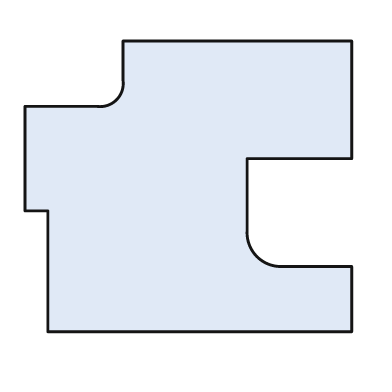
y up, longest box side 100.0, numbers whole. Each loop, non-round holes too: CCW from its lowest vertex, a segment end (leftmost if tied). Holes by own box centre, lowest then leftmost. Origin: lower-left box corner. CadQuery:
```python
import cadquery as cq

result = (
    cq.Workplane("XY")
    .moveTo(7.0, 0.0)
    .lineTo(100.0, 0.0)
    .lineTo(100.0, 20.0)
    .lineTo(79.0, 20.0)
    .threePointArc((71.0, 23.0), (68.0, 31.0))
    .lineTo(68.0, 53.0)
    .lineTo(100.0, 53.0)
    .lineTo(100.0, 89.0)
    .lineTo(30.0, 89.0)
    .lineTo(30.0, 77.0)
    .threePointArc((28.0, 71.0), (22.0, 69.0))
    .lineTo(0.0, 69.0)
    .lineTo(0.0, 37.0)
    .lineTo(7.0, 37.0)
    .close()
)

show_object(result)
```